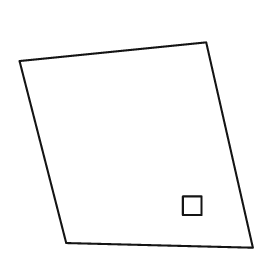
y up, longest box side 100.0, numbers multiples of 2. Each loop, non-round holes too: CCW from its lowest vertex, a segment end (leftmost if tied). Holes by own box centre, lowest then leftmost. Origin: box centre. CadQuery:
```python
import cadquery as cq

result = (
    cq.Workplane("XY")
    .moveTo(50.0, -44.0)
    .lineTo(30.0, 44.0)
    .lineTo(-50.0, 36.0)
    .lineTo(-30.0, -42.0)
    .close()
    .moveTo(20.0, -30.0)
    .lineTo(28.0, -30.0)
    .lineTo(28.0, -22.0)
    .lineTo(20.0, -22.0)
    .close()
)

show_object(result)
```